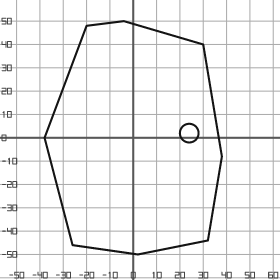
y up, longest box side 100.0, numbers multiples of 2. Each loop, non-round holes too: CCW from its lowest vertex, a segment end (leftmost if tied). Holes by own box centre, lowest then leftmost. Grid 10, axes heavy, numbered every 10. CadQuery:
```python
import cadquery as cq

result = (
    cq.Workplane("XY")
    .moveTo(2.0, -50.0)
    .lineTo(32.0, -44.0)
    .lineTo(38.0, -8.0)
    .lineTo(30.0, 40.0)
    .lineTo(-4.0, 50.0)
    .lineTo(-20.0, 48.0)
    .lineTo(-38.0, 0.0)
    .lineTo(-26.0, -46.0)
    .close()
    .moveTo(24.0, 2.0)
    .circle(4.0)
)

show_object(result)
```